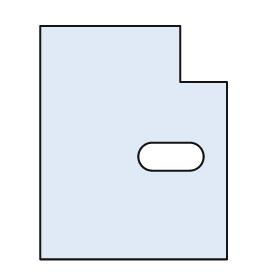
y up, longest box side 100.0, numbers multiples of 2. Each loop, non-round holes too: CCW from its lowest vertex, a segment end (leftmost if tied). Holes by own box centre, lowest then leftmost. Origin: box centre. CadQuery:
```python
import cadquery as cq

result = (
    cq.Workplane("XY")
    .moveTo(-40.0, -50.0)
    .lineTo(40.0, -50.0)
    .lineTo(40.0, 26.0)
    .lineTo(20.0, 26.0)
    .lineTo(20.0, 50.0)
    .lineTo(-40.0, 50.0)
    .close()
    .moveTo(8.0, -12.0)
    .lineTo(24.0, -12.0)
    .threePointArc((30.0, -6.0), (24.0, 0.0))
    .lineTo(8.0, 0.0)
    .threePointArc((2.0, -6.0), (8.0, -12.0))
    .close()
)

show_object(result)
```